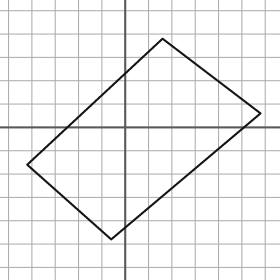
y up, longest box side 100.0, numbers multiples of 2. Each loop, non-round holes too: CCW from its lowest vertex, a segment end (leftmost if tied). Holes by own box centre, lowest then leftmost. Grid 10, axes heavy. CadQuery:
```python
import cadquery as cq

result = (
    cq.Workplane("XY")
    .moveTo(-6.0, -48.0)
    .lineTo(58.0, 6.0)
    .lineTo(16.0, 38.0)
    .lineTo(-42.0, -16.0)
    .close()
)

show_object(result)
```